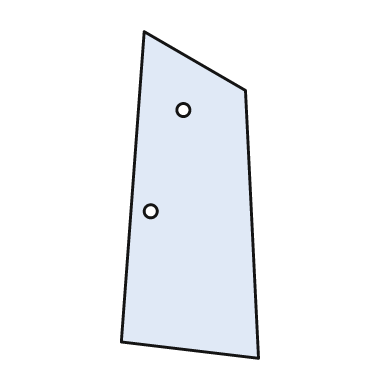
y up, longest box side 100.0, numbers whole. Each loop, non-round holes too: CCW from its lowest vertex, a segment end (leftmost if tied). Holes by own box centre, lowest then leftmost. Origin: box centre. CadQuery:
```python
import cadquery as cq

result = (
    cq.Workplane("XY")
    .moveTo(21.0, -50.0)
    .lineTo(17.0, 32.0)
    .lineTo(-14.0, 50.0)
    .lineTo(-21.0, -45.0)
    .close()
    .moveTo(-12.0, -5.0)
    .circle(2.0)
    .moveTo(-2.0, 26.0)
    .circle(2.0)
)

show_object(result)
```